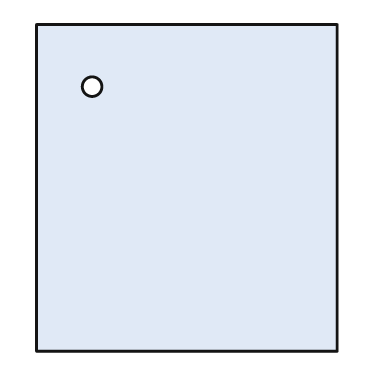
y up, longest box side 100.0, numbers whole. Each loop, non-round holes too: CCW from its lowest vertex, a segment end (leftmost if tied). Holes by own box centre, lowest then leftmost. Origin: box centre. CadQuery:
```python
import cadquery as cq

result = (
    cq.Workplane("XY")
    .moveTo(-46.0, -50.0)
    .lineTo(46.0, -50.0)
    .lineTo(46.0, 50.0)
    .lineTo(-46.0, 50.0)
    .close()
    .moveTo(-29.0, 31.0)
    .circle(3.0)
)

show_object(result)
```